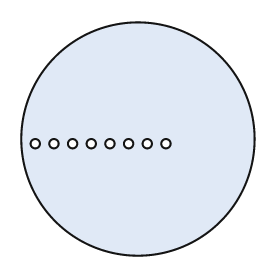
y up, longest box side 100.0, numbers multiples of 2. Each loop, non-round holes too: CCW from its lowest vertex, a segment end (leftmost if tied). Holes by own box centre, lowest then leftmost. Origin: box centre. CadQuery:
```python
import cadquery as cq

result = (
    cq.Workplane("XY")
    .moveTo(0.0, 0.0)
    .circle(50.0)
    .moveTo(-44.0, -2.0)
    .circle(2.0)
    .moveTo(-36.0, -2.0)
    .circle(2.0)
    .moveTo(-28.0, -2.0)
    .circle(2.0)
    .moveTo(-20.0, -2.0)
    .circle(2.0)
    .moveTo(-12.0, -2.0)
    .circle(2.0)
    .moveTo(-4.0, -2.0)
    .circle(2.0)
    .moveTo(4.0, -2.0)
    .circle(2.0)
    .moveTo(12.0, -2.0)
    .circle(2.0)
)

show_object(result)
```